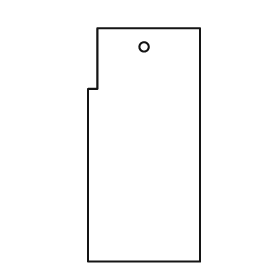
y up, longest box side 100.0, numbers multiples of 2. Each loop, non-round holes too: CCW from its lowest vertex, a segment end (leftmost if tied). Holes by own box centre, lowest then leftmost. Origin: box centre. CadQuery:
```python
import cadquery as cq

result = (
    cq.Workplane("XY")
    .moveTo(-24.0, -50.0)
    .lineTo(24.0, -50.0)
    .lineTo(24.0, 50.0)
    .lineTo(-20.0, 50.0)
    .lineTo(-20.0, 24.0)
    .lineTo(-24.0, 24.0)
    .close()
    .moveTo(0.0, 42.0)
    .circle(2.0)
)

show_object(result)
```